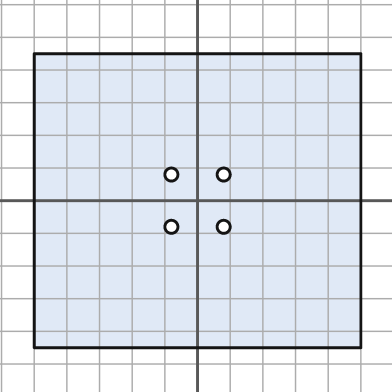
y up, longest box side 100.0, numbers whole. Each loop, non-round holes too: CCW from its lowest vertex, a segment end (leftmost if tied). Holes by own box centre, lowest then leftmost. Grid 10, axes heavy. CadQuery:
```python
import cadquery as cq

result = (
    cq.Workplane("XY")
    .moveTo(-50.0, -45.0)
    .lineTo(50.0, -45.0)
    .lineTo(50.0, 45.0)
    .lineTo(-50.0, 45.0)
    .close()
    .moveTo(-8.0, -8.0)
    .circle(2.0)
    .moveTo(8.0, -8.0)
    .circle(2.0)
    .moveTo(-8.0, 8.0)
    .circle(2.0)
    .moveTo(8.0, 8.0)
    .circle(2.0)
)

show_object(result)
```